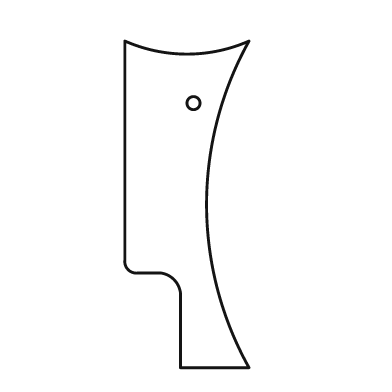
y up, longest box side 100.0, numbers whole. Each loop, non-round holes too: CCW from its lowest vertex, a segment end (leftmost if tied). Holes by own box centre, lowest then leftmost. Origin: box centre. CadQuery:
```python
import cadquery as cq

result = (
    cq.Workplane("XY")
    .moveTo(-2.0, -50.0)
    .lineTo(19.0, -50.0)
    .threePointArc((6.0, 0.0), (19.0, 50.0))
    .threePointArc((0.0, 46.0), (-19.0, 50.0))
    .lineTo(-19.0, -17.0)
    .threePointArc((-18.0, -20.0), (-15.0, -21.0))
    .lineTo(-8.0, -21.0)
    .threePointArc((-4.0, -23.0), (-2.0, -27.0))
    .close()
    .moveTo(2.0, 31.0)
    .circle(2.0)
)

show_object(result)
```